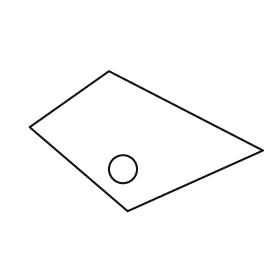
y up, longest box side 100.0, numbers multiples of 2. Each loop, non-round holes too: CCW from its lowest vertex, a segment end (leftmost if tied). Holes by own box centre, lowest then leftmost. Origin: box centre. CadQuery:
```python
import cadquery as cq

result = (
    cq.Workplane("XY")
    .moveTo(-8.0, -30.0)
    .lineTo(50.0, -4.0)
    .lineTo(-16.0, 30.0)
    .lineTo(-50.0, 6.0)
    .close()
    .moveTo(-10.0, -12.0)
    .circle(6.0)
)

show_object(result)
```